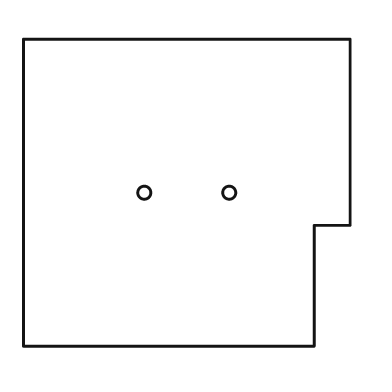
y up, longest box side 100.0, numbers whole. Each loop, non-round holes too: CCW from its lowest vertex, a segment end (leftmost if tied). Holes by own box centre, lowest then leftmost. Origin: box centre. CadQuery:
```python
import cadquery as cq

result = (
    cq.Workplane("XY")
    .moveTo(-50.0, -47.0)
    .lineTo(39.0, -47.0)
    .lineTo(39.0, -10.0)
    .lineTo(50.0, -10.0)
    .lineTo(50.0, 47.0)
    .lineTo(-50.0, 47.0)
    .close()
    .moveTo(-13.0, 0.0)
    .circle(2.0)
    .moveTo(13.0, 0.0)
    .circle(2.0)
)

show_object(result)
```